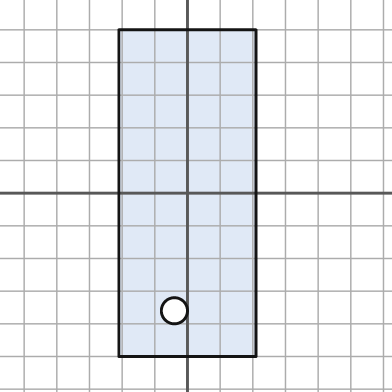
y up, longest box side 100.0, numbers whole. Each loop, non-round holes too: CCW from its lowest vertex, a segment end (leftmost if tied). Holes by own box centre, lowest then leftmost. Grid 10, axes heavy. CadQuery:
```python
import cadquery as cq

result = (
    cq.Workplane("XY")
    .moveTo(-21.0, -50.0)
    .lineTo(21.0, -50.0)
    .lineTo(21.0, 50.0)
    .lineTo(-21.0, 50.0)
    .close()
    .moveTo(-4.0, -36.0)
    .circle(4.0)
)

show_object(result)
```